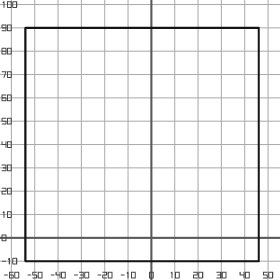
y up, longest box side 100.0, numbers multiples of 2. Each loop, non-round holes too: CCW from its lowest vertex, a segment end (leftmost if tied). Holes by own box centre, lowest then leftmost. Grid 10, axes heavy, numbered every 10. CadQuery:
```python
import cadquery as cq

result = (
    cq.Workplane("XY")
    .moveTo(-54.0, -10.0)
    .lineTo(46.0, -10.0)
    .lineTo(46.0, 90.0)
    .lineTo(-54.0, 90.0)
    .close()
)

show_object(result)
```